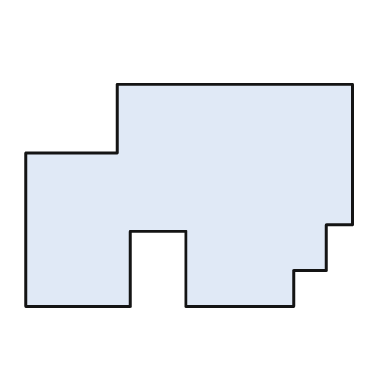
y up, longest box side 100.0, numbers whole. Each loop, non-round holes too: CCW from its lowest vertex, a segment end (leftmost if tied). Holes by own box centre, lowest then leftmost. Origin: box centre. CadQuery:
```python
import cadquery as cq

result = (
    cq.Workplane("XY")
    .moveTo(-50.0, -34.0)
    .lineTo(-18.0, -34.0)
    .lineTo(-18.0, -11.0)
    .lineTo(-1.0, -11.0)
    .lineTo(-1.0, -34.0)
    .lineTo(32.0, -34.0)
    .lineTo(32.0, -23.0)
    .lineTo(42.0, -23.0)
    .lineTo(42.0, -9.0)
    .lineTo(50.0, -9.0)
    .lineTo(50.0, 34.0)
    .lineTo(-22.0, 34.0)
    .lineTo(-22.0, 13.0)
    .lineTo(-50.0, 13.0)
    .close()
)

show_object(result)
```